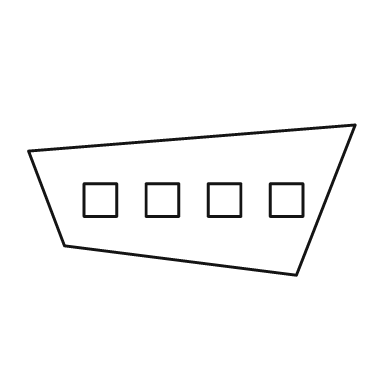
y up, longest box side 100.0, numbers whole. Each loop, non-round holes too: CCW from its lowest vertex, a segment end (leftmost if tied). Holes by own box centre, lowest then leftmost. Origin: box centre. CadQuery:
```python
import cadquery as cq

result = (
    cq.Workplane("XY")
    .moveTo(32.0, -23.0)
    .lineTo(50.0, 23.0)
    .lineTo(-50.0, 15.0)
    .lineTo(-39.0, -14.0)
    .close()
    .moveTo(-33.0, -5.0)
    .lineTo(-23.0, -5.0)
    .lineTo(-23.0, 5.0)
    .lineTo(-33.0, 5.0)
    .close()
    .moveTo(-14.0, -5.0)
    .lineTo(-4.0, -5.0)
    .lineTo(-4.0, 5.0)
    .lineTo(-14.0, 5.0)
    .close()
    .moveTo(5.0, -5.0)
    .lineTo(15.0, -5.0)
    .lineTo(15.0, 5.0)
    .lineTo(5.0, 5.0)
    .close()
    .moveTo(24.0, -5.0)
    .lineTo(34.0, -5.0)
    .lineTo(34.0, 5.0)
    .lineTo(24.0, 5.0)
    .close()
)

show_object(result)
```